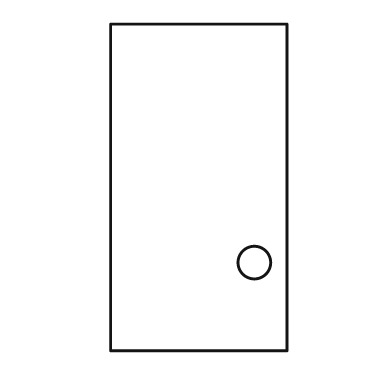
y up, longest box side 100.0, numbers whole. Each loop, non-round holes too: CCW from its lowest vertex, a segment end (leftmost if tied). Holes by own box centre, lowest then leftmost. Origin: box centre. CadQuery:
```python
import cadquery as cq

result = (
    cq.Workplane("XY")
    .moveTo(-27.0, -50.0)
    .lineTo(27.0, -50.0)
    .lineTo(27.0, 50.0)
    .lineTo(-27.0, 50.0)
    .close()
    .moveTo(17.0, -23.0)
    .circle(5.0)
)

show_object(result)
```